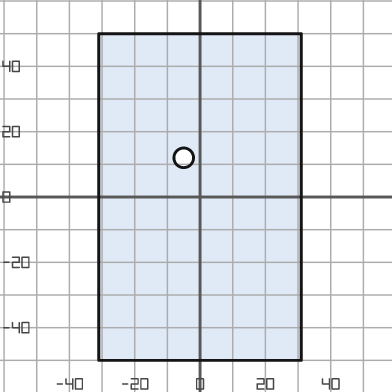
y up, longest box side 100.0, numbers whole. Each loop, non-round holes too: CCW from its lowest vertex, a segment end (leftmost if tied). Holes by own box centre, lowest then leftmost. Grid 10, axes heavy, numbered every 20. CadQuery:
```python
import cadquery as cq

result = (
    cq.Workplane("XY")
    .moveTo(-31.0, -50.0)
    .lineTo(31.0, -50.0)
    .lineTo(31.0, 50.0)
    .lineTo(-31.0, 50.0)
    .close()
    .moveTo(-5.0, 12.0)
    .circle(3.0)
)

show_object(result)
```